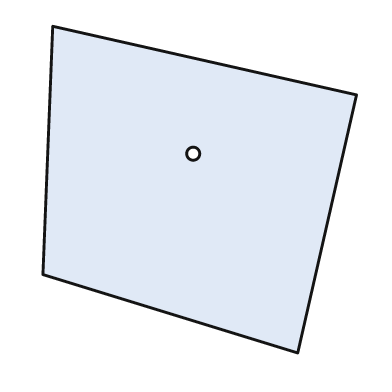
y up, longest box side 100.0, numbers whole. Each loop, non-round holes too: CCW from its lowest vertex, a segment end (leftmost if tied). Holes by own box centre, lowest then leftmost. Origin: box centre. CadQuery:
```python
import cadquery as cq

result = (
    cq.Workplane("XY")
    .moveTo(30.0, -50.0)
    .lineTo(48.0, 29.0)
    .lineTo(-45.0, 50.0)
    .lineTo(-48.0, -26.0)
    .close()
    .moveTo(-2.0, 11.0)
    .circle(2.0)
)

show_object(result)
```